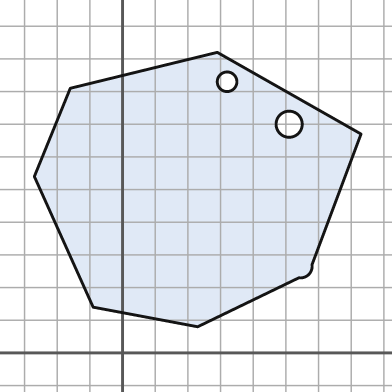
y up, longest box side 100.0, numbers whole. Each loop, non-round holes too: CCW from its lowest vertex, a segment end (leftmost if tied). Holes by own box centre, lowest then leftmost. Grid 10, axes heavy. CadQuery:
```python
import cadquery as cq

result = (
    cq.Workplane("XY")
    .moveTo(23.0, 8.0)
    .lineTo(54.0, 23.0)
    .threePointArc((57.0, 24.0), (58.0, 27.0))
    .lineTo(73.0, 67.0)
    .lineTo(29.0, 92.0)
    .lineTo(-16.0, 81.0)
    .lineTo(-27.0, 54.0)
    .lineTo(-9.0, 14.0)
    .close()
    .moveTo(51.0, 70.0)
    .circle(4.0)
    .moveTo(32.0, 83.0)
    .circle(3.0)
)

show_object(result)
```